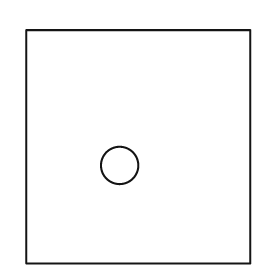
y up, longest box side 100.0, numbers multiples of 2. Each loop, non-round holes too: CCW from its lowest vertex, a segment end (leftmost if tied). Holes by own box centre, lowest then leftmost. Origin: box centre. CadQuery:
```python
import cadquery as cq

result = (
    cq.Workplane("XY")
    .moveTo(-48.0, -50.0)
    .lineTo(48.0, -50.0)
    .lineTo(48.0, 50.0)
    .lineTo(-48.0, 50.0)
    .close()
    .moveTo(-8.0, -8.0)
    .circle(8.0)
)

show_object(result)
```